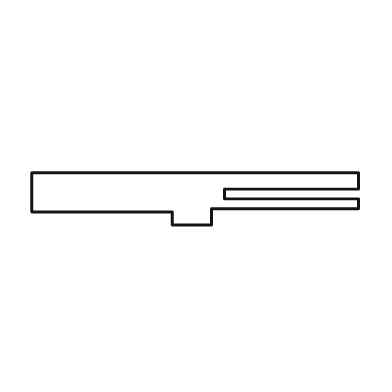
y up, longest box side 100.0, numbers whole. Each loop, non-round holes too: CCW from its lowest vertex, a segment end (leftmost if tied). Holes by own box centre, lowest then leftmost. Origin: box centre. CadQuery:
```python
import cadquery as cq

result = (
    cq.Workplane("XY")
    .moveTo(-7.0, -8.0)
    .lineTo(5.0, -8.0)
    .lineTo(5.0, -3.0)
    .lineTo(50.0, -3.0)
    .lineTo(50.0, 0.0)
    .lineTo(9.0, 0.0)
    .lineTo(9.0, 3.0)
    .lineTo(50.0, 3.0)
    .lineTo(50.0, 8.0)
    .lineTo(-50.0, 8.0)
    .lineTo(-50.0, -4.0)
    .lineTo(-7.0, -4.0)
    .close()
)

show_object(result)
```